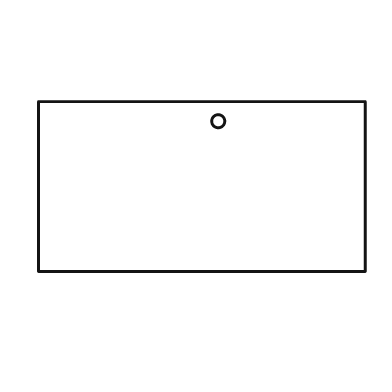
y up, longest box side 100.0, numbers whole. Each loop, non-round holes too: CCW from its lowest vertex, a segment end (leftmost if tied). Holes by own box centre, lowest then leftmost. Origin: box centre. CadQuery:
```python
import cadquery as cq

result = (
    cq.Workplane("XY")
    .moveTo(-50.0, -26.0)
    .lineTo(50.0, -26.0)
    .lineTo(50.0, 26.0)
    .lineTo(-50.0, 26.0)
    .close()
    .moveTo(5.0, 20.0)
    .circle(2.0)
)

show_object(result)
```